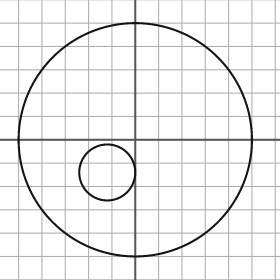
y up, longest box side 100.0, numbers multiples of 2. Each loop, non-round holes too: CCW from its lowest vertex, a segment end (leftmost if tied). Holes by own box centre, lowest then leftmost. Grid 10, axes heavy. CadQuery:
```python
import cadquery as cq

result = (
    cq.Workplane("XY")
    .moveTo(0.0, 0.0)
    .circle(50.0)
    .moveTo(-12.0, -14.0)
    .circle(12.0)
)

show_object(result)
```